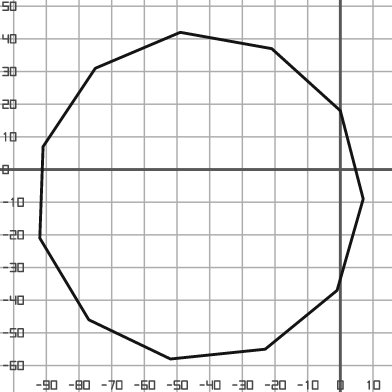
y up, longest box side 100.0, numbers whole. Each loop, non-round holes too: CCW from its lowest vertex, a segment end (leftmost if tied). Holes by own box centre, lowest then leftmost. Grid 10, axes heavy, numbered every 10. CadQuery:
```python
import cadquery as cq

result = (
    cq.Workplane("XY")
    .moveTo(-52.0, -58.0)
    .lineTo(-23.0, -55.0)
    .lineTo(-1.0, -37.0)
    .lineTo(7.0, -9.0)
    .lineTo(0.0, 18.0)
    .lineTo(-21.0, 37.0)
    .lineTo(-49.0, 42.0)
    .lineTo(-75.0, 31.0)
    .lineTo(-91.0, 7.0)
    .lineTo(-92.0, -21.0)
    .lineTo(-77.0, -46.0)
    .close()
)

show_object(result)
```